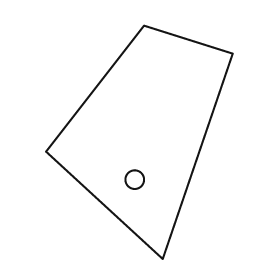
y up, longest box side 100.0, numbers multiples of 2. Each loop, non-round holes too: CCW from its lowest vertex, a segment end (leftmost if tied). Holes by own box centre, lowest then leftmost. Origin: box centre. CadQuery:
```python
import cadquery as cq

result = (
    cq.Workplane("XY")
    .moveTo(10.0, -50.0)
    .lineTo(40.0, 38.0)
    .lineTo(2.0, 50.0)
    .lineTo(-40.0, -4.0)
    .close()
    .moveTo(-2.0, -16.0)
    .circle(4.0)
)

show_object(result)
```